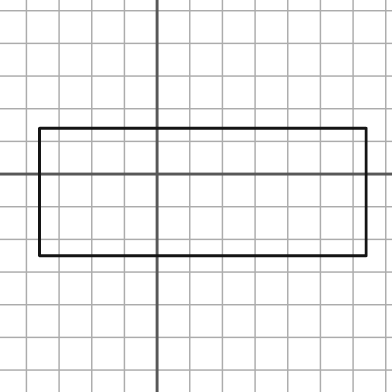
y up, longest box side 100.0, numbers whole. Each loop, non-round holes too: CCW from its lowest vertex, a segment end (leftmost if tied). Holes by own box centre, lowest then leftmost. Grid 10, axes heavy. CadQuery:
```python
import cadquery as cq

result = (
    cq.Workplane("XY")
    .moveTo(-36.0, -25.0)
    .lineTo(64.0, -25.0)
    .lineTo(64.0, 14.0)
    .lineTo(-36.0, 14.0)
    .close()
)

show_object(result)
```